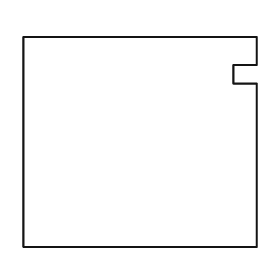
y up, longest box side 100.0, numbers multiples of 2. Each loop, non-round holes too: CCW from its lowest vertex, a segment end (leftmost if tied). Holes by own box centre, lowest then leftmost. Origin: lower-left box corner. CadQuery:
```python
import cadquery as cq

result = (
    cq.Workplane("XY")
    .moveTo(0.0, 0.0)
    .lineTo(100.0, 0.0)
    .lineTo(100.0, 70.0)
    .lineTo(90.0, 70.0)
    .lineTo(90.0, 78.0)
    .lineTo(100.0, 78.0)
    .lineTo(100.0, 90.0)
    .lineTo(0.0, 90.0)
    .close()
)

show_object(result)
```